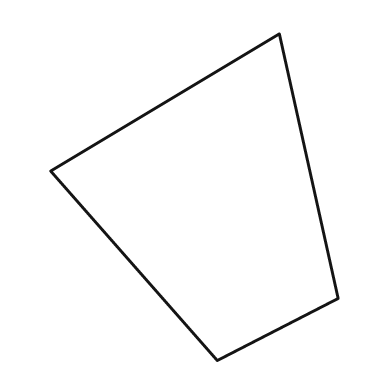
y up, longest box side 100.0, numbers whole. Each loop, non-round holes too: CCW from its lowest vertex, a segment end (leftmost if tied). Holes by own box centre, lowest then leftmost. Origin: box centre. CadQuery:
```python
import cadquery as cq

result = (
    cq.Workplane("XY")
    .moveTo(7.0, -50.0)
    .lineTo(44.0, -31.0)
    .lineTo(26.0, 50.0)
    .lineTo(-44.0, 8.0)
    .close()
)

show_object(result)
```